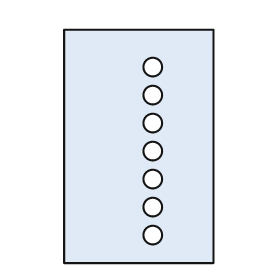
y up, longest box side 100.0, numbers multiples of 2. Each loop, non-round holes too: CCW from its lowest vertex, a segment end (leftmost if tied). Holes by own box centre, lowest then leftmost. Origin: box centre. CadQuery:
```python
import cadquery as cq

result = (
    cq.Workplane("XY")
    .moveTo(-32.0, -50.0)
    .lineTo(32.0, -50.0)
    .lineTo(32.0, 50.0)
    .lineTo(-32.0, 50.0)
    .close()
    .moveTo(6.0, -38.0)
    .circle(4.0)
    .moveTo(6.0, -26.0)
    .circle(4.0)
    .moveTo(6.0, -14.0)
    .circle(4.0)
    .moveTo(6.0, -2.0)
    .circle(4.0)
    .moveTo(6.0, 10.0)
    .circle(4.0)
    .moveTo(6.0, 22.0)
    .circle(4.0)
    .moveTo(6.0, 34.0)
    .circle(4.0)
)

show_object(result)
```